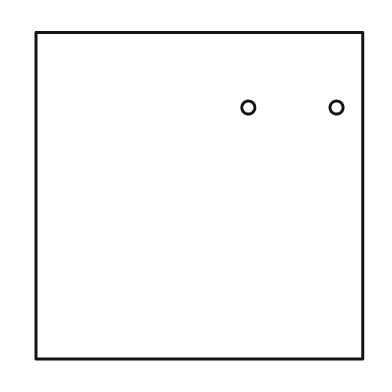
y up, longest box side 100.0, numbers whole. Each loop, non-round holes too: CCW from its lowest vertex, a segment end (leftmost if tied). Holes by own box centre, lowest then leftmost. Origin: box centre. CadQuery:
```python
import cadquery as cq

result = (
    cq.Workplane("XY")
    .moveTo(-50.0, -50.0)
    .lineTo(50.0, -50.0)
    .lineTo(50.0, 50.0)
    .lineTo(-50.0, 50.0)
    .close()
    .moveTo(15.0, 27.0)
    .circle(2.0)
    .moveTo(42.0, 27.0)
    .circle(2.0)
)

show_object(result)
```